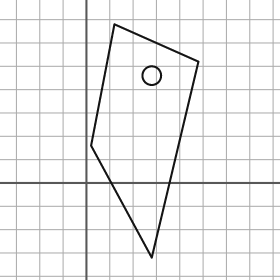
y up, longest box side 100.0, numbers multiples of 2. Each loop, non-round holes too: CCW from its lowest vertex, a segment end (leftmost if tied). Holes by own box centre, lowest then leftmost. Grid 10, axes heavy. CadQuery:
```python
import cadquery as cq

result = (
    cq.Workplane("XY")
    .moveTo(28.0, -32.0)
    .lineTo(48.0, 52.0)
    .lineTo(12.0, 68.0)
    .lineTo(2.0, 16.0)
    .close()
    .moveTo(28.0, 46.0)
    .circle(4.0)
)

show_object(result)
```